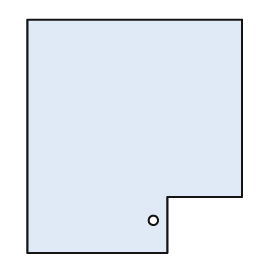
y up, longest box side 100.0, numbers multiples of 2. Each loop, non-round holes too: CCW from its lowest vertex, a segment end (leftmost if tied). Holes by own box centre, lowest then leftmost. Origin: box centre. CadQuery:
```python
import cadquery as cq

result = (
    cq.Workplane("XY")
    .moveTo(-46.0, -50.0)
    .lineTo(14.0, -50.0)
    .lineTo(14.0, -26.0)
    .lineTo(46.0, -26.0)
    .lineTo(46.0, 50.0)
    .lineTo(-46.0, 50.0)
    .close()
    .moveTo(8.0, -36.0)
    .circle(2.0)
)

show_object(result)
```